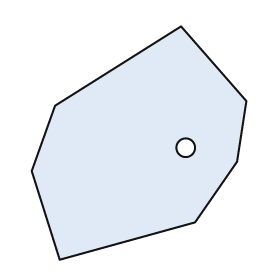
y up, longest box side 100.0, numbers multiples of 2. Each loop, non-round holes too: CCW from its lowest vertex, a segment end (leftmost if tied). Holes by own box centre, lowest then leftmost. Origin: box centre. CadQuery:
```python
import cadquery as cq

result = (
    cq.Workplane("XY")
    .moveTo(-34.0, -50.0)
    .lineTo(24.0, -34.0)
    .lineTo(42.0, -8.0)
    .lineTo(46.0, 18.0)
    .lineTo(18.0, 50.0)
    .lineTo(-36.0, 16.0)
    .lineTo(-46.0, -12.0)
    .close()
    .moveTo(20.0, -2.0)
    .circle(4.0)
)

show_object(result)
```